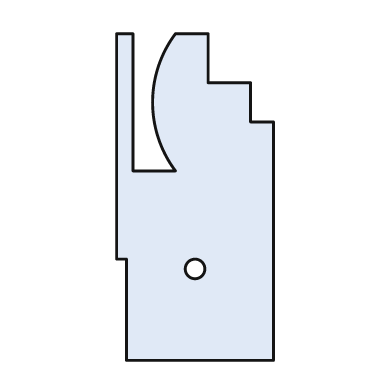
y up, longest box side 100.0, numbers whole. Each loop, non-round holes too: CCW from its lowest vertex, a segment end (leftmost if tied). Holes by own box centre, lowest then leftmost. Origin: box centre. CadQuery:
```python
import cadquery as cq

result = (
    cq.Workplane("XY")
    .moveTo(-21.0, -50.0)
    .lineTo(24.0, -50.0)
    .lineTo(24.0, 23.0)
    .lineTo(17.0, 23.0)
    .lineTo(17.0, 35.0)
    .lineTo(4.0, 35.0)
    .lineTo(4.0, 50.0)
    .lineTo(-6.0, 50.0)
    .threePointArc((-13.0, 29.0), (-6.0, 8.0))
    .lineTo(-19.0, 8.0)
    .lineTo(-19.0, 50.0)
    .lineTo(-24.0, 50.0)
    .lineTo(-24.0, -19.0)
    .lineTo(-21.0, -19.0)
    .close()
    .moveTo(0.0, -22.0)
    .circle(3.0)
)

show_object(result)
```